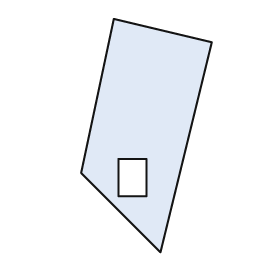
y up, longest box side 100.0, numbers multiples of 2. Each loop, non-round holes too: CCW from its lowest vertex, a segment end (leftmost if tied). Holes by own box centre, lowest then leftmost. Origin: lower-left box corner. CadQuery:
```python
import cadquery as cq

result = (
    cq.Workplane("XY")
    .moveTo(34.0, 0.0)
    .lineTo(56.0, 90.0)
    .lineTo(14.0, 100.0)
    .lineTo(0.0, 34.0)
    .close()
    .moveTo(16.0, 24.0)
    .lineTo(28.0, 24.0)
    .lineTo(28.0, 40.0)
    .lineTo(16.0, 40.0)
    .close()
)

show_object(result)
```